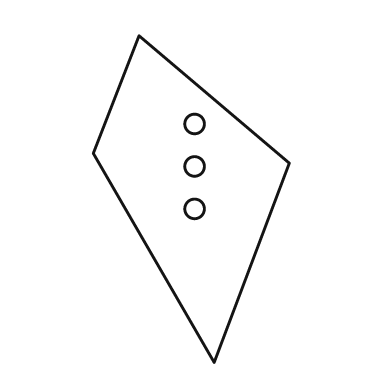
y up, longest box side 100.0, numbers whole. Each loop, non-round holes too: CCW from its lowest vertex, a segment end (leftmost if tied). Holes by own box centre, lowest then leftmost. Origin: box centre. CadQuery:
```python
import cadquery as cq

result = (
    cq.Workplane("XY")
    .moveTo(7.0, -50.0)
    .lineTo(30.0, 11.0)
    .lineTo(-16.0, 50.0)
    .lineTo(-30.0, 14.0)
    .close()
    .moveTo(1.0, -3.0)
    .circle(3.0)
    .moveTo(1.0, 10.0)
    .circle(3.0)
    .moveTo(1.0, 23.0)
    .circle(3.0)
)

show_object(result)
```